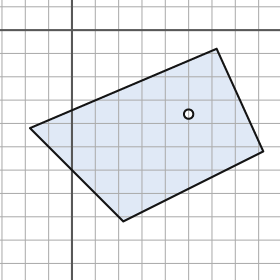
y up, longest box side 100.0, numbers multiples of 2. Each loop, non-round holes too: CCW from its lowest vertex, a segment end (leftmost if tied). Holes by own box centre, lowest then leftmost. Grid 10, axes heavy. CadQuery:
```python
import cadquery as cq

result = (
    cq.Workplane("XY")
    .moveTo(22.0, -82.0)
    .lineTo(82.0, -52.0)
    .lineTo(62.0, -8.0)
    .lineTo(-18.0, -42.0)
    .close()
    .moveTo(50.0, -36.0)
    .circle(2.0)
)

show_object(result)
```